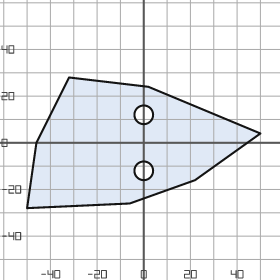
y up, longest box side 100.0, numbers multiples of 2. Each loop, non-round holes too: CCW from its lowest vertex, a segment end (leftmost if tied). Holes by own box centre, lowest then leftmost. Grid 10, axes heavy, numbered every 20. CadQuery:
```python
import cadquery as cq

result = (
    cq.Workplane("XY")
    .moveTo(-50.0, -28.0)
    .lineTo(-6.0, -26.0)
    .lineTo(22.0, -16.0)
    .lineTo(50.0, 4.0)
    .lineTo(2.0, 24.0)
    .lineTo(-32.0, 28.0)
    .lineTo(-46.0, 0.0)
    .close()
    .moveTo(0.0, -12.0)
    .circle(4.0)
    .moveTo(0.0, 12.0)
    .circle(4.0)
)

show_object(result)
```